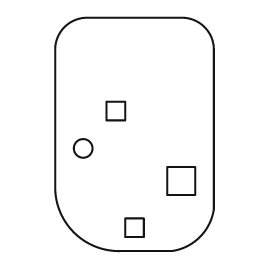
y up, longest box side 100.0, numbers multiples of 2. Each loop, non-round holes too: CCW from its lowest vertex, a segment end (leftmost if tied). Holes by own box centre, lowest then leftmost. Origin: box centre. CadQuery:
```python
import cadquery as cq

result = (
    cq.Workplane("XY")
    .moveTo(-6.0, -50.0)
    .lineTo(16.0, -50.0)
    .threePointArc((28.0, -44.0), (34.0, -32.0))
    .lineTo(34.0, 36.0)
    .threePointArc((30.0, 46.0), (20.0, 50.0))
    .lineTo(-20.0, 50.0)
    .threePointArc((-30.0, 46.0), (-34.0, 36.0))
    .lineTo(-34.0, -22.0)
    .threePointArc((-26.0, -42.0), (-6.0, -50.0))
    .close()
    .moveTo(-4.0, -44.0)
    .lineTo(4.0, -44.0)
    .lineTo(4.0, -36.0)
    .lineTo(-4.0, -36.0)
    .close()
    .moveTo(14.0, -26.0)
    .lineTo(26.0, -26.0)
    .lineTo(26.0, -14.0)
    .lineTo(14.0, -14.0)
    .close()
    .moveTo(-22.0, -6.0)
    .circle(4.0)
    .moveTo(-12.0, 6.0)
    .lineTo(-4.0, 6.0)
    .lineTo(-4.0, 14.0)
    .lineTo(-12.0, 14.0)
    .close()
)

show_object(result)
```